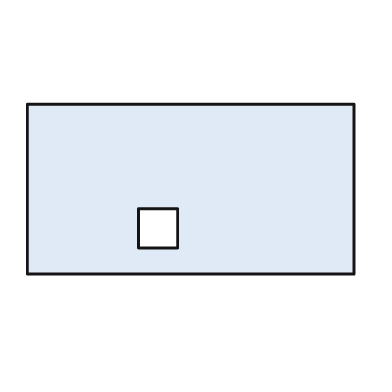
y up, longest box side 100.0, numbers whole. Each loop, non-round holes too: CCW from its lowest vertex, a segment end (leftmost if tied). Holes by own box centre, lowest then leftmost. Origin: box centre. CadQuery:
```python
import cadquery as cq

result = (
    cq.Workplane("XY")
    .moveTo(-50.0, -26.0)
    .lineTo(50.0, -26.0)
    .lineTo(50.0, 26.0)
    .lineTo(-50.0, 26.0)
    .close()
    .moveTo(-16.0, -18.0)
    .lineTo(-4.0, -18.0)
    .lineTo(-4.0, -6.0)
    .lineTo(-16.0, -6.0)
    .close()
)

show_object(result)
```